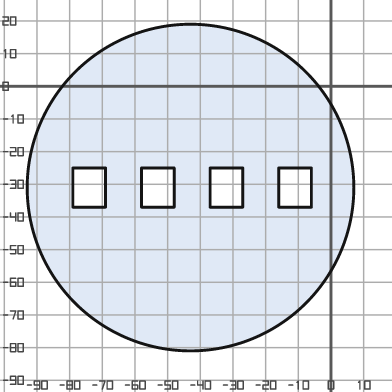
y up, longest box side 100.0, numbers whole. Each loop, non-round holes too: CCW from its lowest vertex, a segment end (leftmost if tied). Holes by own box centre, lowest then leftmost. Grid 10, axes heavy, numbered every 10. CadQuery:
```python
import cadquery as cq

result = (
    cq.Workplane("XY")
    .moveTo(-43.0, -31.0)
    .circle(50.0)
    .moveTo(-79.0, -37.0)
    .lineTo(-69.0, -37.0)
    .lineTo(-69.0, -25.0)
    .lineTo(-79.0, -25.0)
    .close()
    .moveTo(-58.0, -37.0)
    .lineTo(-48.0, -37.0)
    .lineTo(-48.0, -25.0)
    .lineTo(-58.0, -25.0)
    .close()
    .moveTo(-37.0, -37.0)
    .lineTo(-27.0, -37.0)
    .lineTo(-27.0, -25.0)
    .lineTo(-37.0, -25.0)
    .close()
    .moveTo(-16.0, -37.0)
    .lineTo(-6.0, -37.0)
    .lineTo(-6.0, -25.0)
    .lineTo(-16.0, -25.0)
    .close()
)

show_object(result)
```